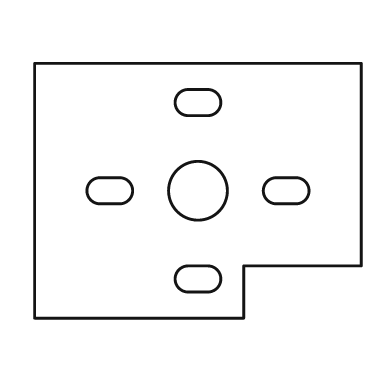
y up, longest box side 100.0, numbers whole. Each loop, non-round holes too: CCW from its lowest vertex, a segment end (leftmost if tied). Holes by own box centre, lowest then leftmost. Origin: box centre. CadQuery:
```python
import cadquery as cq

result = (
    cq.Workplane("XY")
    .moveTo(-50.0, -39.0)
    .lineTo(14.0, -39.0)
    .lineTo(14.0, -23.0)
    .lineTo(50.0, -23.0)
    .lineTo(50.0, 39.0)
    .lineTo(-50.0, 39.0)
    .close()
    .moveTo(-3.0, -31.0)
    .lineTo(3.0, -31.0)
    .threePointArc((7.0, -27.0), (3.0, -23.0))
    .lineTo(-3.0, -23.0)
    .threePointArc((-7.0, -27.0), (-3.0, -31.0))
    .close()
    .moveTo(-30.0, -4.0)
    .lineTo(-24.0, -4.0)
    .threePointArc((-20.0, 0.0), (-24.0, 4.0))
    .lineTo(-30.0, 4.0)
    .threePointArc((-34.0, 0.0), (-30.0, -4.0))
    .close()
    .moveTo(0.0, 0.0)
    .circle(9.0)
    .moveTo(24.0, -4.0)
    .lineTo(30.0, -4.0)
    .threePointArc((34.0, 0.0), (30.0, 4.0))
    .lineTo(24.0, 4.0)
    .threePointArc((20.0, 0.0), (24.0, -4.0))
    .close()
    .moveTo(-3.0, 23.0)
    .lineTo(3.0, 23.0)
    .threePointArc((7.0, 27.0), (3.0, 31.0))
    .lineTo(-3.0, 31.0)
    .threePointArc((-7.0, 27.0), (-3.0, 23.0))
    .close()
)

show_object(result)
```